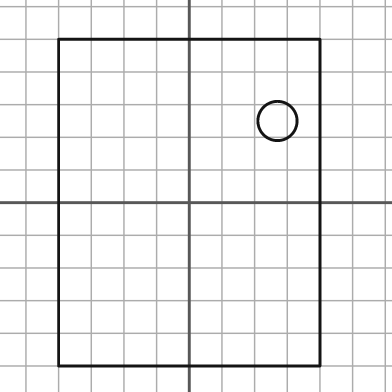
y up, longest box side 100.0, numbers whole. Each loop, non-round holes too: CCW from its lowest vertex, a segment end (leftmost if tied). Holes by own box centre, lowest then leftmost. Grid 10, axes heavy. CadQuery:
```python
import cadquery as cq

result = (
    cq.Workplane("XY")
    .moveTo(-40.0, -50.0)
    .lineTo(40.0, -50.0)
    .lineTo(40.0, 50.0)
    .lineTo(-40.0, 50.0)
    .close()
    .moveTo(27.0, 25.0)
    .circle(6.0)
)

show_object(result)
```